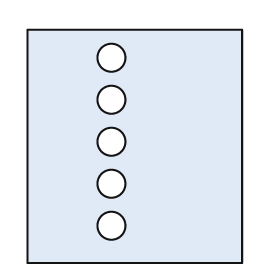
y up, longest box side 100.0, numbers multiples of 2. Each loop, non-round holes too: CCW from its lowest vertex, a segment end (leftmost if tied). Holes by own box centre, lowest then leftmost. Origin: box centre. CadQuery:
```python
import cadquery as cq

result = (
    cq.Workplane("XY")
    .moveTo(-46.0, -50.0)
    .lineTo(46.0, -50.0)
    .lineTo(46.0, 50.0)
    .lineTo(-46.0, 50.0)
    .close()
    .moveTo(-10.0, -34.0)
    .circle(6.0)
    .moveTo(-10.0, -16.0)
    .circle(6.0)
    .moveTo(-10.0, 2.0)
    .circle(6.0)
    .moveTo(-10.0, 20.0)
    .circle(6.0)
    .moveTo(-10.0, 38.0)
    .circle(6.0)
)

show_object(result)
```